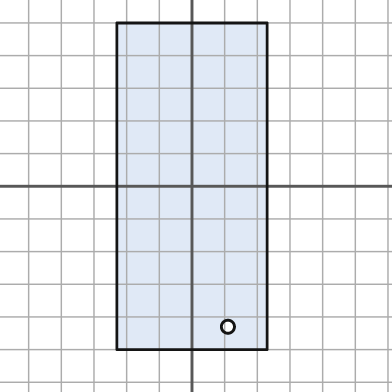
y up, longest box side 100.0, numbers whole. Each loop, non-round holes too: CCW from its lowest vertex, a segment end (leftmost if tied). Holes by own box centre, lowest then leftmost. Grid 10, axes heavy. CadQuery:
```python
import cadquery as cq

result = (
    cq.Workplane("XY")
    .moveTo(-23.0, -50.0)
    .lineTo(23.0, -50.0)
    .lineTo(23.0, 50.0)
    .lineTo(-23.0, 50.0)
    .close()
    .moveTo(11.0, -43.0)
    .circle(2.0)
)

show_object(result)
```